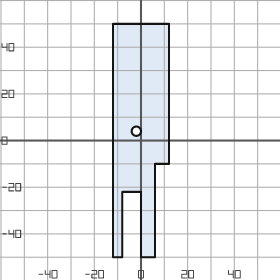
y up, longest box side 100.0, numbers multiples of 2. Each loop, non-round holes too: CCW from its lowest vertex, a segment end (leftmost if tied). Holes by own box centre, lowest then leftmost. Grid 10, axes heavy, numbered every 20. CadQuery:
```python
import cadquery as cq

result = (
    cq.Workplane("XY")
    .moveTo(-12.0, -50.0)
    .lineTo(-8.0, -50.0)
    .lineTo(-8.0, -22.0)
    .lineTo(0.0, -22.0)
    .lineTo(0.0, -50.0)
    .lineTo(6.0, -50.0)
    .lineTo(6.0, -10.0)
    .lineTo(12.0, -10.0)
    .lineTo(12.0, 50.0)
    .lineTo(-12.0, 50.0)
    .close()
    .moveTo(-2.0, 4.0)
    .circle(2.0)
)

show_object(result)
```